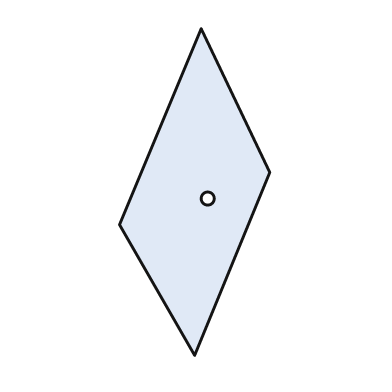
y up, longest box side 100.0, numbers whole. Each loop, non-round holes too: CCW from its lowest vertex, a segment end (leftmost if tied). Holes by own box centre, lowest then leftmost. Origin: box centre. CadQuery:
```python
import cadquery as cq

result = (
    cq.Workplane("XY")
    .moveTo(0.0, -50.0)
    .lineTo(23.0, 6.0)
    .lineTo(2.0, 50.0)
    .lineTo(-23.0, -10.0)
    .close()
    .moveTo(4.0, -2.0)
    .circle(2.0)
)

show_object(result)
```